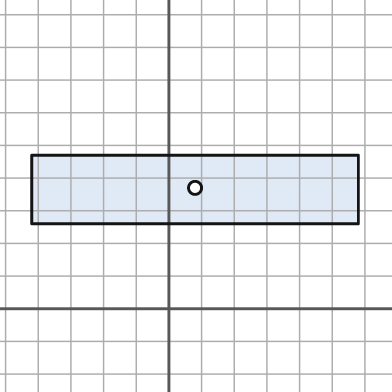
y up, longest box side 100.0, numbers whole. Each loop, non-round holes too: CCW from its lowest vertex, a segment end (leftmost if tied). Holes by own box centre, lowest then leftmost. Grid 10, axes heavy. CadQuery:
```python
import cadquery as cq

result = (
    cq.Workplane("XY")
    .moveTo(-42.0, 26.0)
    .lineTo(58.0, 26.0)
    .lineTo(58.0, 47.0)
    .lineTo(-42.0, 47.0)
    .close()
    .moveTo(8.0, 37.0)
    .circle(2.0)
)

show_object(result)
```